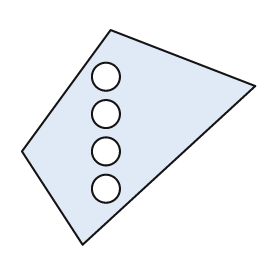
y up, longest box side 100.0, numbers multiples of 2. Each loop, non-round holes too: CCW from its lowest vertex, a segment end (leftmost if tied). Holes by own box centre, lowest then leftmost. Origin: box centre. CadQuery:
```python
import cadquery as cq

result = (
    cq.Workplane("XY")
    .moveTo(-24.0, -46.0)
    .lineTo(50.0, 22.0)
    .lineTo(-12.0, 46.0)
    .lineTo(-50.0, -6.0)
    .close()
    .moveTo(-14.0, -22.0)
    .circle(6.0)
    .moveTo(-14.0, -6.0)
    .circle(6.0)
    .moveTo(-14.0, 10.0)
    .circle(6.0)
    .moveTo(-14.0, 26.0)
    .circle(6.0)
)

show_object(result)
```